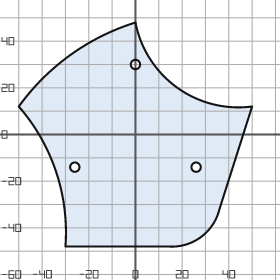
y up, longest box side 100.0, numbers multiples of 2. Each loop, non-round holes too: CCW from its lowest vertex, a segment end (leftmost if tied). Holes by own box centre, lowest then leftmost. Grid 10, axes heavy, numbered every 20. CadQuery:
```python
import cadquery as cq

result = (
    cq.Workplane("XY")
    .moveTo(-30.0, -48.0)
    .lineTo(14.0, -48.0)
    .threePointArc((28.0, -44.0), (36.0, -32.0))
    .lineTo(50.0, 12.0)
    .threePointArc((18.0, 20.0), (0.0, 48.0))
    .threePointArc((-28.0, 34.0), (-50.0, 12.0))
    .threePointArc((-34.0, -16.0), (-30.0, -48.0))
    .close()
    .moveTo(-26.0, -14.0)
    .circle(2.0)
    .moveTo(26.0, -14.0)
    .circle(2.0)
    .moveTo(0.0, 30.0)
    .circle(2.0)
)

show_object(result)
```